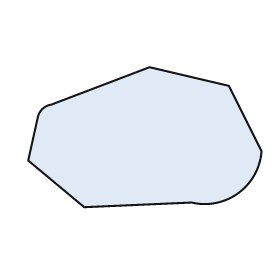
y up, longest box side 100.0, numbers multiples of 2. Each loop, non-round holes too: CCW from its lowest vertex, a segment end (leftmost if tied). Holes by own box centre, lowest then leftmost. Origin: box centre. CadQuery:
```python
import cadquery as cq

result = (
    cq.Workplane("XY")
    .moveTo(-26.0, -30.0)
    .lineTo(20.0, -28.0)
    .threePointArc((40.0, -24.0), (50.0, -6.0))
    .lineTo(36.0, 22.0)
    .lineTo(2.0, 30.0)
    .lineTo(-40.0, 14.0)
    .threePointArc((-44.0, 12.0), (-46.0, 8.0))
    .lineTo(-50.0, -10.0)
    .close()
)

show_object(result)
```